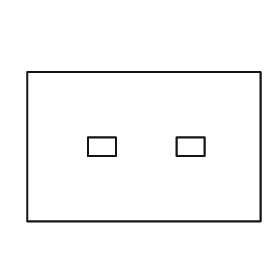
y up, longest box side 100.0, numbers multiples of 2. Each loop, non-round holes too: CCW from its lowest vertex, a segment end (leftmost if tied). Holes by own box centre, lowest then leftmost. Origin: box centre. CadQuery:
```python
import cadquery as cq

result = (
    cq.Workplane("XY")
    .moveTo(-50.0, -32.0)
    .lineTo(50.0, -32.0)
    .lineTo(50.0, 32.0)
    .lineTo(-50.0, 32.0)
    .close()
    .moveTo(-24.0, -4.0)
    .lineTo(-12.0, -4.0)
    .lineTo(-12.0, 4.0)
    .lineTo(-24.0, 4.0)
    .close()
    .moveTo(14.0, -4.0)
    .lineTo(26.0, -4.0)
    .lineTo(26.0, 4.0)
    .lineTo(14.0, 4.0)
    .close()
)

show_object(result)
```